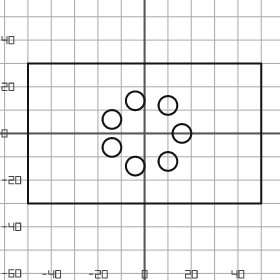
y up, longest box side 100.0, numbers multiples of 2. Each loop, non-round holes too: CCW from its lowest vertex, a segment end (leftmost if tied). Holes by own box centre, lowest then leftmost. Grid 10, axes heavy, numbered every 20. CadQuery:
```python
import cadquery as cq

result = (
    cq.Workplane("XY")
    .moveTo(-50.0, -30.0)
    .lineTo(50.0, -30.0)
    .lineTo(50.0, 30.0)
    .lineTo(-50.0, 30.0)
    .close()
    .moveTo(-4.0, -14.0)
    .circle(4.0)
    .moveTo(10.0, -12.0)
    .circle(4.0)
    .moveTo(-14.0, -6.0)
    .circle(4.0)
    .moveTo(16.0, 0.0)
    .circle(4.0)
    .moveTo(-14.0, 6.0)
    .circle(4.0)
    .moveTo(10.0, 12.0)
    .circle(4.0)
    .moveTo(-4.0, 14.0)
    .circle(4.0)
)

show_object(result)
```